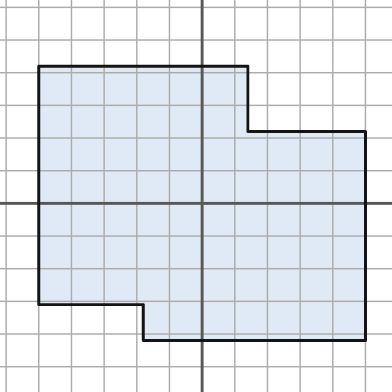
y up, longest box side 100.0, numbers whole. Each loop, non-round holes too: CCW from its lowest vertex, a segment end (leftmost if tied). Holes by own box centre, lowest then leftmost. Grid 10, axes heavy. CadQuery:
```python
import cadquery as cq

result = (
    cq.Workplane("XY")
    .moveTo(-18.0, -42.0)
    .lineTo(50.0, -42.0)
    .lineTo(50.0, 22.0)
    .lineTo(14.0, 22.0)
    .lineTo(14.0, 42.0)
    .lineTo(-50.0, 42.0)
    .lineTo(-50.0, -31.0)
    .lineTo(-18.0, -31.0)
    .close()
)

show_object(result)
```